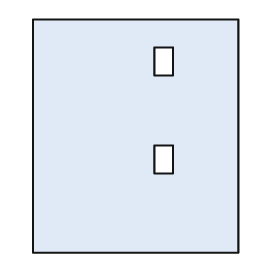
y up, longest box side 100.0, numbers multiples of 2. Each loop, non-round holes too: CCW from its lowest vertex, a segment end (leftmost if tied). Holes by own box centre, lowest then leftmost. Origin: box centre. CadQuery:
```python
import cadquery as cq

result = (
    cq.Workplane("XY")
    .moveTo(-44.0, -50.0)
    .lineTo(44.0, -50.0)
    .lineTo(44.0, 50.0)
    .lineTo(-44.0, 50.0)
    .close()
    .moveTo(8.0, -16.0)
    .lineTo(16.0, -16.0)
    .lineTo(16.0, -4.0)
    .lineTo(8.0, -4.0)
    .close()
    .moveTo(8.0, 26.0)
    .lineTo(16.0, 26.0)
    .lineTo(16.0, 38.0)
    .lineTo(8.0, 38.0)
    .close()
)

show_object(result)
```